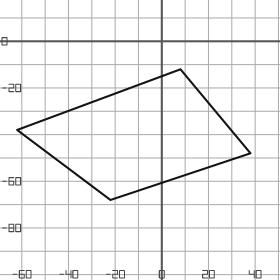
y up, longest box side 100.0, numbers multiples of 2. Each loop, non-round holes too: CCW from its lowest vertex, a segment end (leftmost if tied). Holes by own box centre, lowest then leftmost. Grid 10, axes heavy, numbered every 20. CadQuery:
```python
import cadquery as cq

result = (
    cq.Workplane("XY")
    .moveTo(-22.0, -68.0)
    .lineTo(38.0, -48.0)
    .lineTo(8.0, -12.0)
    .lineTo(-62.0, -38.0)
    .close()
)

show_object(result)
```